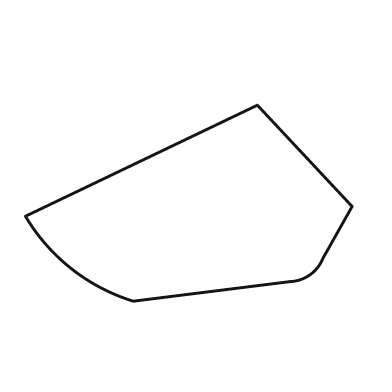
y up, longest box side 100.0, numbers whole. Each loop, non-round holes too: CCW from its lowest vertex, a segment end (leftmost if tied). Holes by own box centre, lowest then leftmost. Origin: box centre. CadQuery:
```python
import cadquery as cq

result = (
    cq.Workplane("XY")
    .moveTo(-17.0, -30.0)
    .lineTo(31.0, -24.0)
    .threePointArc((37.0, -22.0), (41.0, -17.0))
    .lineTo(50.0, -1.0)
    .lineTo(21.0, 30.0)
    .lineTo(-50.0, -4.0)
    .threePointArc((-36.0, -20.0), (-17.0, -30.0))
    .close()
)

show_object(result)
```